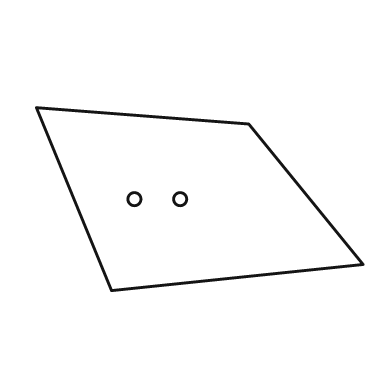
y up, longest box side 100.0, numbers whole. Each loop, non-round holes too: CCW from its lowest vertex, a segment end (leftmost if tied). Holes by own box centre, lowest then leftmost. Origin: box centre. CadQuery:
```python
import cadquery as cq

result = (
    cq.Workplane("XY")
    .moveTo(-27.0, -28.0)
    .lineTo(50.0, -20.0)
    .lineTo(15.0, 23.0)
    .lineTo(-50.0, 28.0)
    .close()
    .moveTo(-20.0, 0.0)
    .circle(2.0)
    .moveTo(-6.0, 0.0)
    .circle(2.0)
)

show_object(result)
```